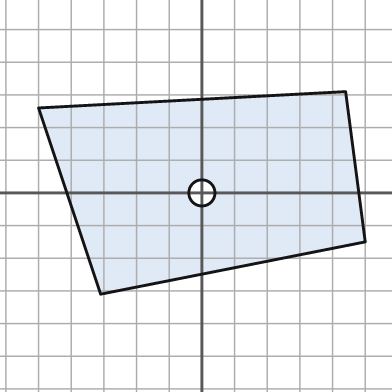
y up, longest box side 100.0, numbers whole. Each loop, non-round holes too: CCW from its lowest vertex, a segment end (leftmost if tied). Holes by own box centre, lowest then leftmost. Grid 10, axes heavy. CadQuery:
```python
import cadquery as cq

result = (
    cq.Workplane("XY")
    .moveTo(-31.0, -31.0)
    .lineTo(50.0, -15.0)
    .lineTo(44.0, 31.0)
    .lineTo(-50.0, 26.0)
    .close()
    .moveTo(0.0, 0.0)
    .circle(4.0)
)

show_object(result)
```